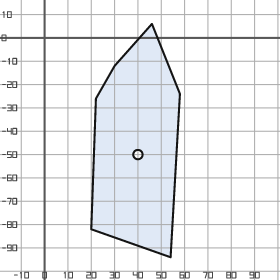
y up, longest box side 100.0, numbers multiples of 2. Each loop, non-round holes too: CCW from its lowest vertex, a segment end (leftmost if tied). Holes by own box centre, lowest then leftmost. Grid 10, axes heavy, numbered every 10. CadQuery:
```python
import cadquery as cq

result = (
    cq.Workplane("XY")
    .moveTo(54.0, -94.0)
    .lineTo(58.0, -24.0)
    .lineTo(46.0, 6.0)
    .lineTo(30.0, -12.0)
    .lineTo(22.0, -26.0)
    .lineTo(20.0, -82.0)
    .close()
    .moveTo(40.0, -50.0)
    .circle(2.0)
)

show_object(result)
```